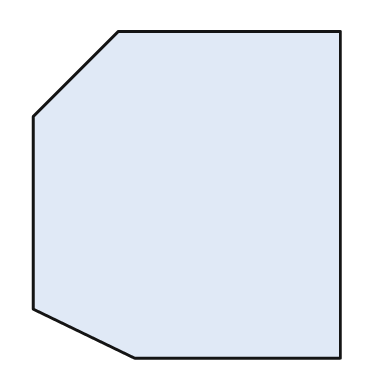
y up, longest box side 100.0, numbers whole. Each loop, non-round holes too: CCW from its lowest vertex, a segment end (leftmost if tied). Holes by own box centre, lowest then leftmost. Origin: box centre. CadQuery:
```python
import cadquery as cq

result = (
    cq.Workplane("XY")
    .moveTo(-16.0, -50.0)
    .lineTo(47.0, -50.0)
    .lineTo(47.0, 50.0)
    .lineTo(-21.0, 50.0)
    .lineTo(-47.0, 24.0)
    .lineTo(-47.0, -35.0)
    .close()
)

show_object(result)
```